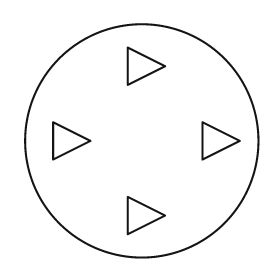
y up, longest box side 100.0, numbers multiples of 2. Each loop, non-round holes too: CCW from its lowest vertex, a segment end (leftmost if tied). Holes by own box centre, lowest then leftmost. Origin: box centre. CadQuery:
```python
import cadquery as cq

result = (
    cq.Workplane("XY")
    .moveTo(0.0, 0.0)
    .circle(50.0)
    .moveTo(-6.0, -40.0)
    .lineTo(10.0, -32.0)
    .lineTo(-6.0, -24.0)
    .close()
    .moveTo(-38.0, -8.0)
    .lineTo(-22.0, 0.0)
    .lineTo(-38.0, 8.0)
    .close()
    .moveTo(26.0, -8.0)
    .lineTo(42.0, 0.0)
    .lineTo(26.0, 8.0)
    .close()
    .moveTo(-6.0, 24.0)
    .lineTo(10.0, 32.0)
    .lineTo(-6.0, 40.0)
    .close()
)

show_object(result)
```